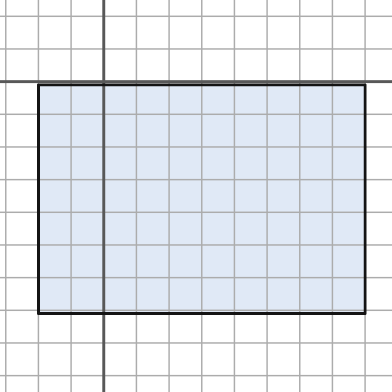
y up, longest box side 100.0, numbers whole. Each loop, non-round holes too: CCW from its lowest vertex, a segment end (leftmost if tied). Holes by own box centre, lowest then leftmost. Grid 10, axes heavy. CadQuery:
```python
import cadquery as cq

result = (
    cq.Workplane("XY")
    .moveTo(-20.0, -71.0)
    .lineTo(80.0, -71.0)
    .lineTo(80.0, -1.0)
    .lineTo(-20.0, -1.0)
    .close()
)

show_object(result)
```